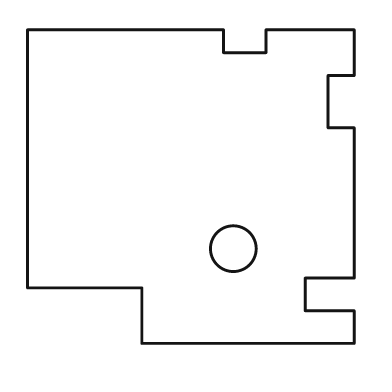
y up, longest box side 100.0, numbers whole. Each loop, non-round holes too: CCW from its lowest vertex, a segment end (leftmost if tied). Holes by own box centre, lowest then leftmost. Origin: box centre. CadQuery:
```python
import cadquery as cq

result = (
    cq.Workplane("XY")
    .moveTo(-15.0, -48.0)
    .lineTo(50.0, -48.0)
    .lineTo(50.0, -38.0)
    .lineTo(35.0, -38.0)
    .lineTo(35.0, -28.0)
    .lineTo(50.0, -28.0)
    .lineTo(50.0, 18.0)
    .lineTo(42.0, 18.0)
    .lineTo(42.0, 34.0)
    .lineTo(50.0, 34.0)
    .lineTo(50.0, 48.0)
    .lineTo(23.0, 48.0)
    .lineTo(23.0, 41.0)
    .lineTo(10.0, 41.0)
    .lineTo(10.0, 48.0)
    .lineTo(-50.0, 48.0)
    .lineTo(-50.0, -31.0)
    .lineTo(-15.0, -31.0)
    .close()
    .moveTo(13.0, -19.0)
    .circle(7.0)
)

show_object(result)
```